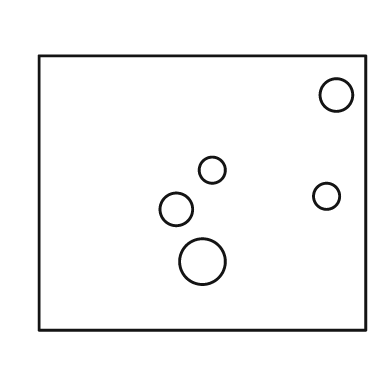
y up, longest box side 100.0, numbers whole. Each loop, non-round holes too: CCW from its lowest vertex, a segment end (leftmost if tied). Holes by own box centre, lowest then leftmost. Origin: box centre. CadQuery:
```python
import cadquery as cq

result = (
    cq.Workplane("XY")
    .moveTo(-50.0, -42.0)
    .lineTo(50.0, -42.0)
    .lineTo(50.0, 42.0)
    .lineTo(-50.0, 42.0)
    .close()
    .moveTo(0.0, -21.0)
    .circle(7.0)
    .moveTo(-8.0, -5.0)
    .circle(5.0)
    .moveTo(38.0, -1.0)
    .circle(4.0)
    .moveTo(3.0, 7.0)
    .circle(4.0)
    .moveTo(41.0, 30.0)
    .circle(5.0)
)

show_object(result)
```